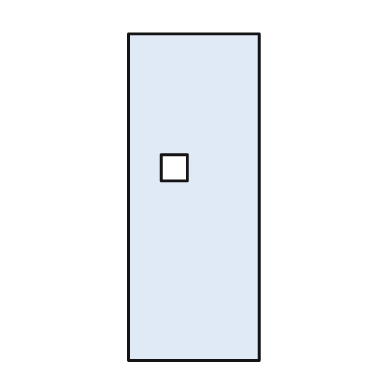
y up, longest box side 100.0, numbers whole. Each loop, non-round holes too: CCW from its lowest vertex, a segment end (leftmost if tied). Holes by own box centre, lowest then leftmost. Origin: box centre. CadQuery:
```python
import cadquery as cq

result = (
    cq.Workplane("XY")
    .moveTo(-20.0, -50.0)
    .lineTo(20.0, -50.0)
    .lineTo(20.0, 50.0)
    .lineTo(-20.0, 50.0)
    .close()
    .moveTo(-10.0, 5.0)
    .lineTo(-2.0, 5.0)
    .lineTo(-2.0, 13.0)
    .lineTo(-10.0, 13.0)
    .close()
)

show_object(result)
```